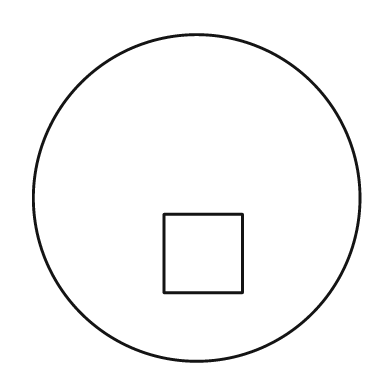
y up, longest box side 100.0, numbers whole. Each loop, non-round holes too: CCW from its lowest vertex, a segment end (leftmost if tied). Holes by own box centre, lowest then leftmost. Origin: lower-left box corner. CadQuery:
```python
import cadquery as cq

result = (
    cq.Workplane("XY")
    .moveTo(50.0, 50.0)
    .circle(50.0)
    .moveTo(40.0, 21.0)
    .lineTo(64.0, 21.0)
    .lineTo(64.0, 45.0)
    .lineTo(40.0, 45.0)
    .close()
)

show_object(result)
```